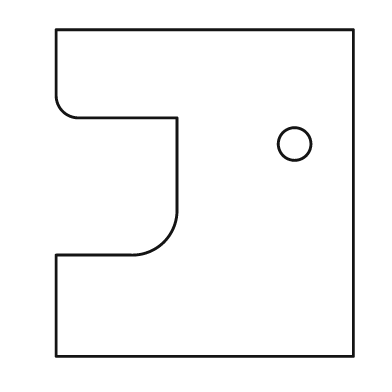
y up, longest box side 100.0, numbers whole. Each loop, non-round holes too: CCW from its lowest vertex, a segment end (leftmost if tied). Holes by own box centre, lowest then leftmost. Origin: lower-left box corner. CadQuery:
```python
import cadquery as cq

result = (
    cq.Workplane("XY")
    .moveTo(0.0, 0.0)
    .lineTo(91.0, 0.0)
    .lineTo(91.0, 100.0)
    .lineTo(0.0, 100.0)
    .lineTo(0.0, 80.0)
    .threePointArc((2.0, 75.0), (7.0, 73.0))
    .lineTo(37.0, 73.0)
    .lineTo(37.0, 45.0)
    .threePointArc((33.0, 35.0), (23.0, 31.0))
    .lineTo(0.0, 31.0)
    .close()
    .moveTo(73.0, 65.0)
    .circle(5.0)
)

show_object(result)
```